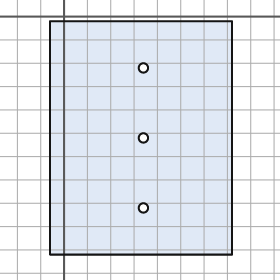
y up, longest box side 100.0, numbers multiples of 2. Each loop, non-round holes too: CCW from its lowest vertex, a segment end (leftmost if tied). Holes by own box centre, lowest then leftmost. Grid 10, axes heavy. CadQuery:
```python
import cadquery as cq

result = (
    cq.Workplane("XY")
    .moveTo(-6.0, -102.0)
    .lineTo(72.0, -102.0)
    .lineTo(72.0, -2.0)
    .lineTo(-6.0, -2.0)
    .close()
    .moveTo(34.0, -82.0)
    .circle(2.0)
    .moveTo(34.0, -52.0)
    .circle(2.0)
    .moveTo(34.0, -22.0)
    .circle(2.0)
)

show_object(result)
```